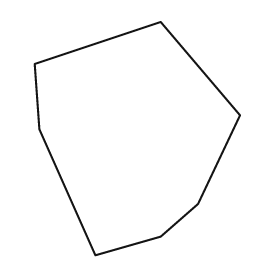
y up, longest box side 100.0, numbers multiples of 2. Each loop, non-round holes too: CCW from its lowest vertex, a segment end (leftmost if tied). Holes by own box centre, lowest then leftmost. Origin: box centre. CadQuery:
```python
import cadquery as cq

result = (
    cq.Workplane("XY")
    .moveTo(-18.0, -50.0)
    .lineTo(10.0, -42.0)
    .lineTo(26.0, -28.0)
    .lineTo(44.0, 10.0)
    .lineTo(10.0, 50.0)
    .lineTo(-44.0, 32.0)
    .lineTo(-42.0, 4.0)
    .close()
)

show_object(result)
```